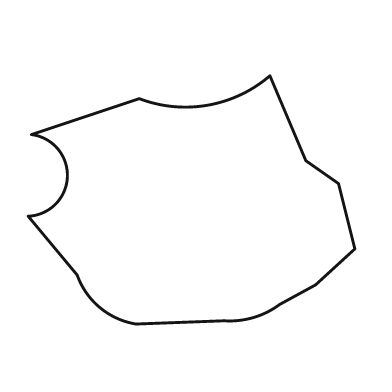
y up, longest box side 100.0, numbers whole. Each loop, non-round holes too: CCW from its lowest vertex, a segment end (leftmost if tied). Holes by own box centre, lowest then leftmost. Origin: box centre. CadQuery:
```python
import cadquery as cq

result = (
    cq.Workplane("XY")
    .moveTo(-17.0, -38.0)
    .lineTo(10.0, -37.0)
    .threePointArc((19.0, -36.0), (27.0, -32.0))
    .lineTo(38.0, -26.0)
    .lineTo(50.0, -15.0)
    .lineTo(45.0, 5.0)
    .lineTo(35.0, 12.0)
    .lineTo(24.0, 38.0)
    .threePointArc((5.0, 29.0), (-16.0, 31.0))
    .lineTo(-49.0, 20.0)
    .threePointArc((-38.0, 7.0), (-50.0, -5.0))
    .lineTo(-35.0, -23.0)
    .threePointArc((-28.0, -33.0), (-17.0, -38.0))
    .close()
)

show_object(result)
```